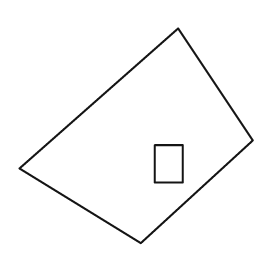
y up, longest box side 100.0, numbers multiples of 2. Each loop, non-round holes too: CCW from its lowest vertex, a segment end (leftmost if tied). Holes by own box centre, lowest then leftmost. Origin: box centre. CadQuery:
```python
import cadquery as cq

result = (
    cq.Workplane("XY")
    .moveTo(2.0, -46.0)
    .lineTo(50.0, -2.0)
    .lineTo(18.0, 46.0)
    .lineTo(-50.0, -14.0)
    .close()
    .moveTo(8.0, -20.0)
    .lineTo(20.0, -20.0)
    .lineTo(20.0, -4.0)
    .lineTo(8.0, -4.0)
    .close()
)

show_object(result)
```